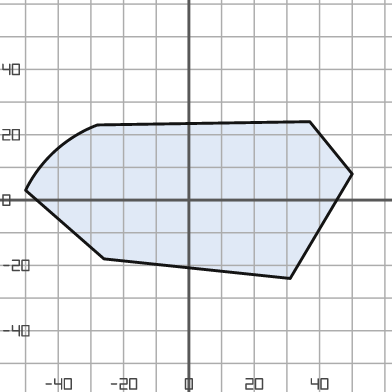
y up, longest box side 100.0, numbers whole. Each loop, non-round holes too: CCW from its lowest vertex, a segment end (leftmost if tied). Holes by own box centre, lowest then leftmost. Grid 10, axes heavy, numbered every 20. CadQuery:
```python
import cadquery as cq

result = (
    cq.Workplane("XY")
    .moveTo(31.0, -24.0)
    .lineTo(50.0, 8.0)
    .lineTo(37.0, 24.0)
    .lineTo(-28.0, 23.0)
    .threePointArc((-41.0, 15.0), (-50.0, 3.0))
    .lineTo(-26.0, -18.0)
    .close()
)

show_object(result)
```